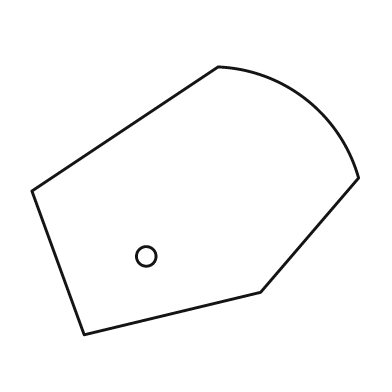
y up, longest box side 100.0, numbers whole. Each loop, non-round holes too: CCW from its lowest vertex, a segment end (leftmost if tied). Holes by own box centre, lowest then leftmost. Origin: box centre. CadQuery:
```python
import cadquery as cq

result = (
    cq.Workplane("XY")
    .moveTo(-34.0, -41.0)
    .lineTo(20.0, -28.0)
    .lineTo(50.0, 7.0)
    .threePointArc((34.0, 31.0), (7.0, 41.0))
    .lineTo(-50.0, 3.0)
    .close()
    .moveTo(-15.0, -17.0)
    .circle(3.0)
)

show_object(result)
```